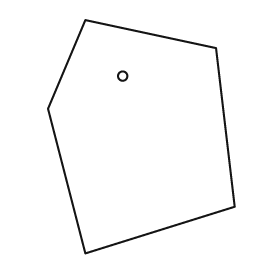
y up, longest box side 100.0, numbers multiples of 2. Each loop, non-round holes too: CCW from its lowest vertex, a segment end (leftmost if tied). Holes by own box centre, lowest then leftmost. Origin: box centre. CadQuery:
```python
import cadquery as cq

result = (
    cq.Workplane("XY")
    .moveTo(-24.0, -50.0)
    .lineTo(40.0, -30.0)
    .lineTo(32.0, 38.0)
    .lineTo(-24.0, 50.0)
    .lineTo(-40.0, 12.0)
    .close()
    .moveTo(-8.0, 26.0)
    .circle(2.0)
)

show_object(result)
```